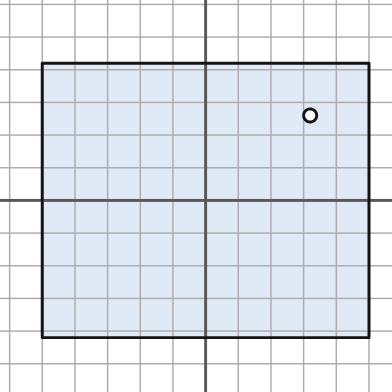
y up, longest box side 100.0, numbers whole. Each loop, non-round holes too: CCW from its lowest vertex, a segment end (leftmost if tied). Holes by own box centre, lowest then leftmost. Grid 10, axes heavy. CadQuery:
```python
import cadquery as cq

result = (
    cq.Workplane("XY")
    .moveTo(-50.0, -42.0)
    .lineTo(50.0, -42.0)
    .lineTo(50.0, 42.0)
    .lineTo(-50.0, 42.0)
    .close()
    .moveTo(32.0, 26.0)
    .circle(2.0)
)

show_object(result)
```